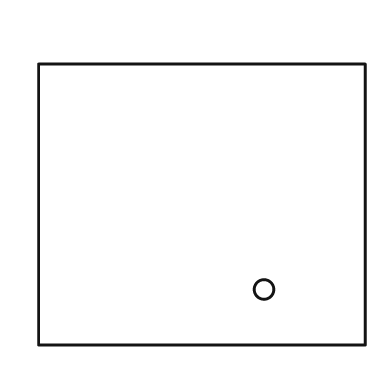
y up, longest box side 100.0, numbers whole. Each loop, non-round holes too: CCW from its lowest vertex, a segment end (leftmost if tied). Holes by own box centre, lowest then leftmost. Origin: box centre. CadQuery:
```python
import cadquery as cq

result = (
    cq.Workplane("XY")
    .moveTo(-50.0, -43.0)
    .lineTo(50.0, -43.0)
    .lineTo(50.0, 43.0)
    .lineTo(-50.0, 43.0)
    .close()
    .moveTo(19.0, -26.0)
    .circle(3.0)
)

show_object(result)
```